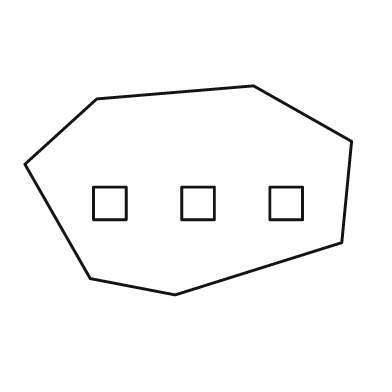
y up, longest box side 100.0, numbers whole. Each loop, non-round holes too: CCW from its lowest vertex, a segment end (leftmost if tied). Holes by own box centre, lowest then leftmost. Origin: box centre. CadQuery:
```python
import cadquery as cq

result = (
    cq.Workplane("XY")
    .moveTo(-4.0, -32.0)
    .lineTo(47.0, -16.0)
    .lineTo(50.0, 15.0)
    .lineTo(20.0, 32.0)
    .lineTo(-28.0, 28.0)
    .lineTo(-50.0, 8.0)
    .lineTo(-30.0, -27.0)
    .close()
    .moveTo(-29.0, -9.0)
    .lineTo(-19.0, -9.0)
    .lineTo(-19.0, 1.0)
    .lineTo(-29.0, 1.0)
    .close()
    .moveTo(-2.0, -9.0)
    .lineTo(8.0, -9.0)
    .lineTo(8.0, 1.0)
    .lineTo(-2.0, 1.0)
    .close()
    .moveTo(25.0, -9.0)
    .lineTo(35.0, -9.0)
    .lineTo(35.0, 1.0)
    .lineTo(25.0, 1.0)
    .close()
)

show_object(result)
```